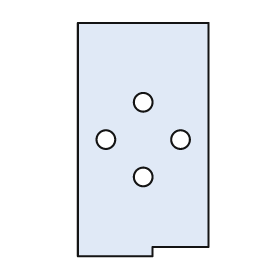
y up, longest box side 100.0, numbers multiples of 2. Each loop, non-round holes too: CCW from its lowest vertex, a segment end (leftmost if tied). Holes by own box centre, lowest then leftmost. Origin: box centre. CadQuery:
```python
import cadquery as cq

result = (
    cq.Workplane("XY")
    .moveTo(-28.0, -50.0)
    .lineTo(4.0, -50.0)
    .lineTo(4.0, -46.0)
    .lineTo(28.0, -46.0)
    .lineTo(28.0, 50.0)
    .lineTo(-28.0, 50.0)
    .close()
    .moveTo(0.0, -16.0)
    .circle(4.0)
    .moveTo(-16.0, 0.0)
    .circle(4.0)
    .moveTo(16.0, 0.0)
    .circle(4.0)
    .moveTo(0.0, 16.0)
    .circle(4.0)
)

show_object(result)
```